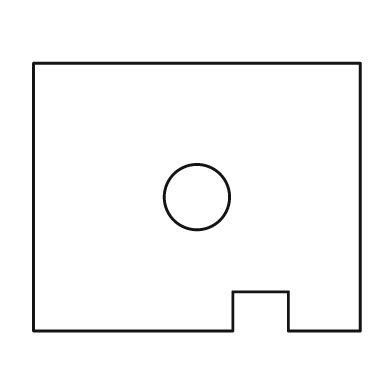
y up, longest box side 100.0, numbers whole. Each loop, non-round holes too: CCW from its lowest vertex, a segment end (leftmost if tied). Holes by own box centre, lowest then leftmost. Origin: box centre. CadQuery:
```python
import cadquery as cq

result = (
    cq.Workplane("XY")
    .moveTo(-50.0, -41.0)
    .lineTo(11.0, -41.0)
    .lineTo(11.0, -29.0)
    .lineTo(28.0, -29.0)
    .lineTo(28.0, -41.0)
    .lineTo(50.0, -41.0)
    .lineTo(50.0, 41.0)
    .lineTo(-50.0, 41.0)
    .close()
    .moveTo(0.0, 0.0)
    .circle(10.0)
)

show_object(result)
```